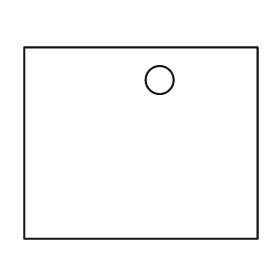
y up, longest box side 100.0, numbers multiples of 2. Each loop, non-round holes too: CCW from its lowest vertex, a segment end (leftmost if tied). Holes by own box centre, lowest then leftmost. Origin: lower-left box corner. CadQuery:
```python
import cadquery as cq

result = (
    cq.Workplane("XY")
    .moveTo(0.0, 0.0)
    .lineTo(100.0, 0.0)
    .lineTo(100.0, 82.0)
    .lineTo(0.0, 82.0)
    .close()
    .moveTo(58.0, 68.0)
    .circle(6.0)
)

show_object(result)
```